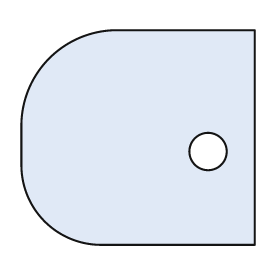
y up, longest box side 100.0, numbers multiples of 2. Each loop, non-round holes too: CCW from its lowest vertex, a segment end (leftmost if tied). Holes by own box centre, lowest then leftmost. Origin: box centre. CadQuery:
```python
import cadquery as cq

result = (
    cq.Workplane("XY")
    .moveTo(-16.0, -46.0)
    .lineTo(50.0, -46.0)
    .lineTo(50.0, 46.0)
    .lineTo(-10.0, 46.0)
    .threePointArc((-38.0, 34.0), (-50.0, 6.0))
    .lineTo(-50.0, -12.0)
    .threePointArc((-40.0, -36.0), (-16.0, -46.0))
    .close()
    .moveTo(30.0, -6.0)
    .circle(8.0)
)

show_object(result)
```